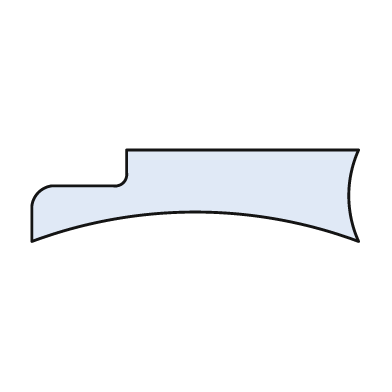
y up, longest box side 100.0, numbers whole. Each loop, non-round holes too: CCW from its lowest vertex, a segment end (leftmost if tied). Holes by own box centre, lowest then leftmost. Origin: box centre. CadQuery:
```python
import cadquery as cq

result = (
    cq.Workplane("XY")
    .moveTo(-50.0, -14.0)
    .threePointArc((0.0, -5.0), (50.0, -14.0))
    .threePointArc((47.0, 0.0), (50.0, 14.0))
    .lineTo(-21.0, 14.0)
    .lineTo(-21.0, 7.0)
    .threePointArc((-22.0, 4.0), (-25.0, 3.0))
    .lineTo(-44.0, 3.0)
    .threePointArc((-48.0, 1.0), (-50.0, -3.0))
    .close()
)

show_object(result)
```